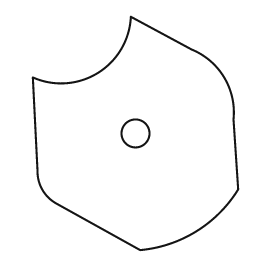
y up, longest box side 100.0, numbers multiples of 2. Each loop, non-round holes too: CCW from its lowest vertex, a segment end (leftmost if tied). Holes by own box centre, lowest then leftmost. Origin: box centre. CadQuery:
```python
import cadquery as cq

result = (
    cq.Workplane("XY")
    .moveTo(2.0, -50.0)
    .threePointArc((26.0, -42.0), (44.0, -24.0))
    .lineTo(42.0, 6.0)
    .threePointArc((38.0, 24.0), (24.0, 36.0))
    .lineTo(-2.0, 50.0)
    .threePointArc((-16.0, 26.0), (-44.0, 24.0))
    .lineTo(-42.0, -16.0)
    .threePointArc((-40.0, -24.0), (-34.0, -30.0))
    .close()
    .moveTo(0.0, 0.0)
    .circle(6.0)
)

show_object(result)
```